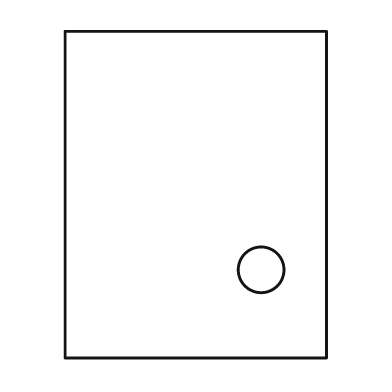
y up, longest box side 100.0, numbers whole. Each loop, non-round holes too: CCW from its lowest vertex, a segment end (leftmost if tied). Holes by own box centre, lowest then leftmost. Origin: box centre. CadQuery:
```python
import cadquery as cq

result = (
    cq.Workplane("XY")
    .moveTo(-40.0, -50.0)
    .lineTo(40.0, -50.0)
    .lineTo(40.0, 50.0)
    .lineTo(-40.0, 50.0)
    .close()
    .moveTo(20.0, -23.0)
    .circle(7.0)
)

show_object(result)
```